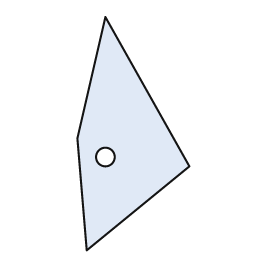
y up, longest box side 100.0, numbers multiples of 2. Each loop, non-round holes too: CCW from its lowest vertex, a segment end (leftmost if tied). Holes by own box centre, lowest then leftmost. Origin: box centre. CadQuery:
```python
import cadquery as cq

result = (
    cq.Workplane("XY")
    .moveTo(-20.0, -50.0)
    .lineTo(24.0, -14.0)
    .lineTo(-12.0, 50.0)
    .lineTo(-24.0, -2.0)
    .close()
    .moveTo(-12.0, -10.0)
    .circle(4.0)
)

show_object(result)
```